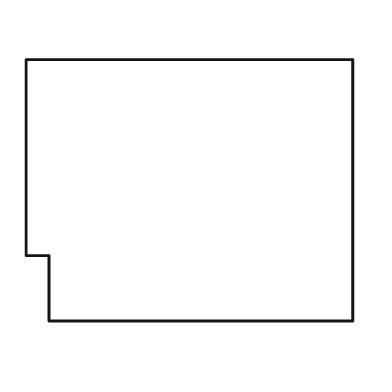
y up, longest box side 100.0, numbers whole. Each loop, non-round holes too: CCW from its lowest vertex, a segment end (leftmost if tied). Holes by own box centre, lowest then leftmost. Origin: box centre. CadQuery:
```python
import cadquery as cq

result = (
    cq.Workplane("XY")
    .moveTo(-43.0, -40.0)
    .lineTo(50.0, -40.0)
    .lineTo(50.0, 40.0)
    .lineTo(-50.0, 40.0)
    .lineTo(-50.0, -20.0)
    .lineTo(-43.0, -20.0)
    .close()
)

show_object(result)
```